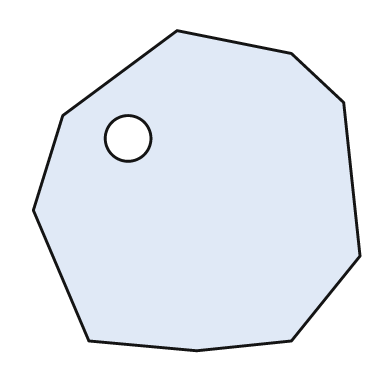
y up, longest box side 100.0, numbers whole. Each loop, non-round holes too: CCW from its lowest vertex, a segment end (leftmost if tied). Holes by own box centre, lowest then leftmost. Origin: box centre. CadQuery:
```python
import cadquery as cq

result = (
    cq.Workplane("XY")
    .moveTo(0.0, -49.0)
    .lineTo(29.0, -46.0)
    .lineTo(50.0, -20.0)
    .lineTo(45.0, 27.0)
    .lineTo(29.0, 42.0)
    .lineTo(-6.0, 49.0)
    .lineTo(-41.0, 23.0)
    .lineTo(-50.0, -6.0)
    .lineTo(-33.0, -46.0)
    .close()
    .moveTo(-21.0, 16.0)
    .circle(7.0)
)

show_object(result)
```